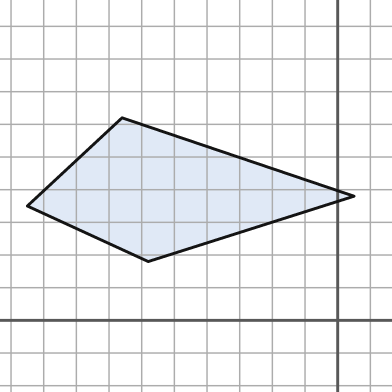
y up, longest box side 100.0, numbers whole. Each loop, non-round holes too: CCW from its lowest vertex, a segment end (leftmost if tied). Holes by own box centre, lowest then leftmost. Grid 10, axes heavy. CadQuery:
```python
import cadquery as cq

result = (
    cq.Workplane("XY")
    .moveTo(-58.0, 18.0)
    .lineTo(5.0, 38.0)
    .lineTo(-66.0, 62.0)
    .lineTo(-95.0, 35.0)
    .close()
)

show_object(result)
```